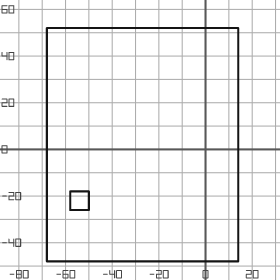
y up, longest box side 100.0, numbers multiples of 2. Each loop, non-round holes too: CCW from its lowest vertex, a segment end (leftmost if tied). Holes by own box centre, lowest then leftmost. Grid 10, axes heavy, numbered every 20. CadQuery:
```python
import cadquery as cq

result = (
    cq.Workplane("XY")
    .moveTo(-68.0, -48.0)
    .lineTo(14.0, -48.0)
    .lineTo(14.0, 52.0)
    .lineTo(-68.0, 52.0)
    .close()
    .moveTo(-58.0, -26.0)
    .lineTo(-50.0, -26.0)
    .lineTo(-50.0, -18.0)
    .lineTo(-58.0, -18.0)
    .close()
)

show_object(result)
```